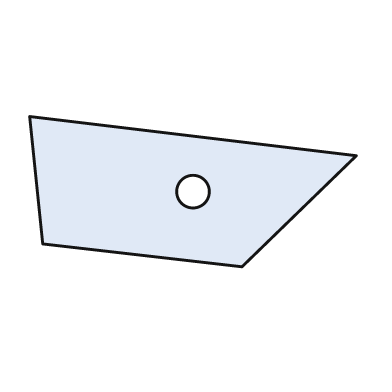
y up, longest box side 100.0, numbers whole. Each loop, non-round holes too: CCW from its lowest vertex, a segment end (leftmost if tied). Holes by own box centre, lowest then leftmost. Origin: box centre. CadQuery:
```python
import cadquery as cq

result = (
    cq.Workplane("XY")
    .moveTo(15.0, -23.0)
    .lineTo(50.0, 11.0)
    .lineTo(-50.0, 23.0)
    .lineTo(-46.0, -16.0)
    .close()
    .moveTo(0.0, 0.0)
    .circle(5.0)
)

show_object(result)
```